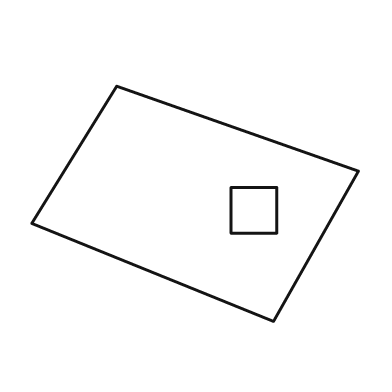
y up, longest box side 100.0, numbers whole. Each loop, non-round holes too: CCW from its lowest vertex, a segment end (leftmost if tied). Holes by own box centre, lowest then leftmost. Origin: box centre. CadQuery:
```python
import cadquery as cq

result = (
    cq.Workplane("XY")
    .moveTo(24.0, -36.0)
    .lineTo(50.0, 10.0)
    .lineTo(-24.0, 36.0)
    .lineTo(-50.0, -6.0)
    .close()
    .moveTo(11.0, -9.0)
    .lineTo(25.0, -9.0)
    .lineTo(25.0, 5.0)
    .lineTo(11.0, 5.0)
    .close()
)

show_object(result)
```